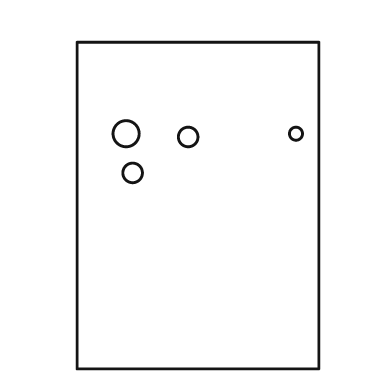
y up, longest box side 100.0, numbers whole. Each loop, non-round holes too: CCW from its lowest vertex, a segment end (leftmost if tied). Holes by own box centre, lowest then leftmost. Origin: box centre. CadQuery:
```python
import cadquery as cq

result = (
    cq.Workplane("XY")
    .moveTo(-37.0, -50.0)
    .lineTo(37.0, -50.0)
    .lineTo(37.0, 50.0)
    .lineTo(-37.0, 50.0)
    .close()
    .moveTo(-20.0, 10.0)
    .circle(3.0)
    .moveTo(-3.0, 21.0)
    .circle(3.0)
    .moveTo(-22.0, 22.0)
    .circle(4.0)
    .moveTo(30.0, 22.0)
    .circle(2.0)
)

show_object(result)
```